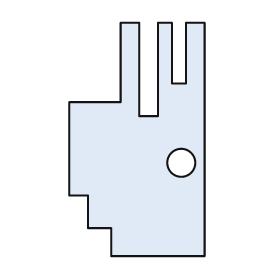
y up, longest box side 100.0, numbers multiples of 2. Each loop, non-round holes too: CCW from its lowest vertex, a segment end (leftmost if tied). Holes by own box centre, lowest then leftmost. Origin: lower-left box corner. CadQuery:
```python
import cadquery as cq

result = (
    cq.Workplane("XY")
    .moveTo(18.0, 0.0)
    .lineTo(58.0, 0.0)
    .lineTo(58.0, 100.0)
    .lineTo(50.0, 100.0)
    .lineTo(50.0, 74.0)
    .lineTo(44.0, 74.0)
    .lineTo(44.0, 100.0)
    .lineTo(38.0, 100.0)
    .lineTo(38.0, 60.0)
    .lineTo(30.0, 60.0)
    .lineTo(30.0, 100.0)
    .lineTo(22.0, 100.0)
    .lineTo(22.0, 66.0)
    .lineTo(0.0, 66.0)
    .lineTo(0.0, 26.0)
    .lineTo(8.0, 26.0)
    .lineTo(8.0, 12.0)
    .lineTo(18.0, 12.0)
    .close()
    .moveTo(48.0, 40.0)
    .circle(6.0)
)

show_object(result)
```